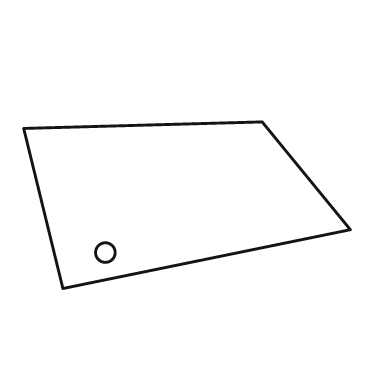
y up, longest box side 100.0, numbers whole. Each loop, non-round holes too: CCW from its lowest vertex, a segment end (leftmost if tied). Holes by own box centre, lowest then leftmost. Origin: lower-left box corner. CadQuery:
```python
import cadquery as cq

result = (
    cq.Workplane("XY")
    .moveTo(12.0, 0.0)
    .lineTo(100.0, 18.0)
    .lineTo(73.0, 51.0)
    .lineTo(0.0, 49.0)
    .close()
    .moveTo(25.0, 11.0)
    .circle(3.0)
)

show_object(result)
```